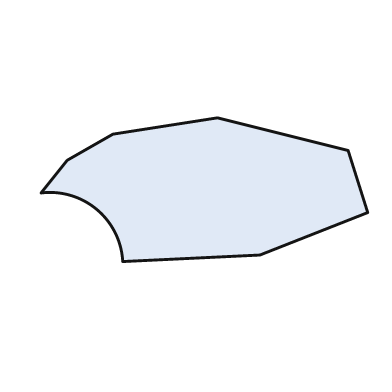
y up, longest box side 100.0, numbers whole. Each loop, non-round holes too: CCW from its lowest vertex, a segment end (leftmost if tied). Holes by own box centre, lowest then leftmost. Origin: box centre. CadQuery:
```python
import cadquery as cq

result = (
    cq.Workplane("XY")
    .moveTo(-25.0, -22.0)
    .lineTo(17.0, -20.0)
    .lineTo(50.0, -7.0)
    .lineTo(44.0, 12.0)
    .lineTo(4.0, 22.0)
    .lineTo(-28.0, 17.0)
    .lineTo(-42.0, 9.0)
    .lineTo(-50.0, -1.0)
    .threePointArc((-33.0, -6.0), (-25.0, -22.0))
    .close()
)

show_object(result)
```